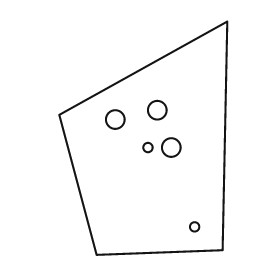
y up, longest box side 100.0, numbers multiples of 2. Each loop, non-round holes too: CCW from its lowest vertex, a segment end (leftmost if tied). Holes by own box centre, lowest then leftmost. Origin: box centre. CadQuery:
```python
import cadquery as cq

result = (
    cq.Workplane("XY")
    .moveTo(-20.0, -50.0)
    .lineTo(34.0, -48.0)
    .lineTo(36.0, 50.0)
    .lineTo(-36.0, 10.0)
    .close()
    .moveTo(22.0, -38.0)
    .circle(2.0)
    .moveTo(2.0, -4.0)
    .circle(2.0)
    .moveTo(12.0, -4.0)
    .circle(4.0)
    .moveTo(-12.0, 8.0)
    .circle(4.0)
    .moveTo(6.0, 12.0)
    .circle(4.0)
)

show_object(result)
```